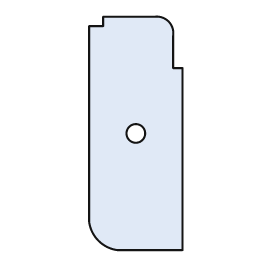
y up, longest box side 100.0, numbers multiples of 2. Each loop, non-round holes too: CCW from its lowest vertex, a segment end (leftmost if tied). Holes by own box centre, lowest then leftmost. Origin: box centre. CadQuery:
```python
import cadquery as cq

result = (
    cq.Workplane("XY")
    .moveTo(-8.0, -50.0)
    .lineTo(20.0, -50.0)
    .lineTo(20.0, 28.0)
    .lineTo(16.0, 28.0)
    .lineTo(16.0, 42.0)
    .threePointArc((14.0, 48.0), (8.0, 50.0))
    .lineTo(-14.0, 50.0)
    .lineTo(-14.0, 46.0)
    .lineTo(-20.0, 46.0)
    .lineTo(-20.0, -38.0)
    .threePointArc((-16.0, -46.0), (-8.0, -50.0))
    .close()
    .moveTo(0.0, 0.0)
    .circle(4.0)
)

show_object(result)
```